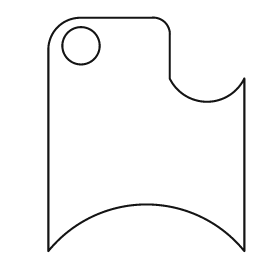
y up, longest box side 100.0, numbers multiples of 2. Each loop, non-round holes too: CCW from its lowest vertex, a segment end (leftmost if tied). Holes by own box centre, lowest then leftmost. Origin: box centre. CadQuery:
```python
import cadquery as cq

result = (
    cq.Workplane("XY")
    .moveTo(-42.0, -50.0)
    .threePointArc((0.0, -30.0), (42.0, -50.0))
    .lineTo(42.0, 24.0)
    .threePointArc((26.0, 14.0), (10.0, 24.0))
    .lineTo(10.0, 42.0)
    .threePointArc((8.0, 48.0), (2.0, 50.0))
    .lineTo(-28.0, 50.0)
    .threePointArc((-38.0, 46.0), (-42.0, 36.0))
    .close()
    .moveTo(-28.0, 38.0)
    .circle(8.0)
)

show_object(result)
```